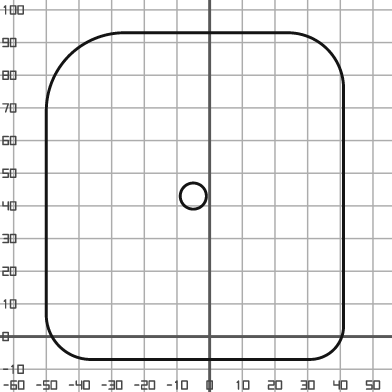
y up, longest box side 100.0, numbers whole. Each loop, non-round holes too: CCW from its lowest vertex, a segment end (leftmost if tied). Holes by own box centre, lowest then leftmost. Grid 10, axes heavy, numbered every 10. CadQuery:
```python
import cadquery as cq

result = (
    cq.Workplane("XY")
    .moveTo(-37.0, -7.0)
    .lineTo(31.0, -7.0)
    .threePointArc((38.0, -4.0), (41.0, 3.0))
    .lineTo(41.0, 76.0)
    .threePointArc((36.0, 88.0), (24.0, 93.0))
    .lineTo(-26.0, 93.0)
    .threePointArc((-43.0, 86.0), (-50.0, 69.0))
    .lineTo(-50.0, 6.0)
    .threePointArc((-46.0, -3.0), (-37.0, -7.0))
    .close()
    .moveTo(-5.0, 43.0)
    .circle(4.0)
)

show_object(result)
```